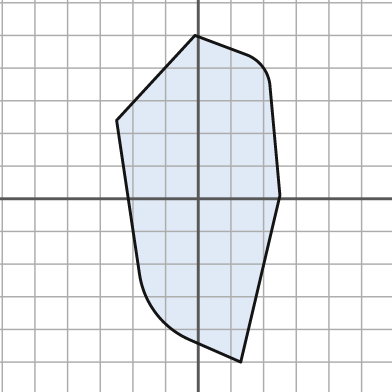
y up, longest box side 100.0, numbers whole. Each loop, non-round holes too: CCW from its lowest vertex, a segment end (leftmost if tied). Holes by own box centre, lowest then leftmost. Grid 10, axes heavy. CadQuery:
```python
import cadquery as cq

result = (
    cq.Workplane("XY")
    .moveTo(13.0, -50.0)
    .lineTo(25.0, 1.0)
    .lineTo(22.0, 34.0)
    .threePointArc((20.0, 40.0), (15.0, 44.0))
    .lineTo(-1.0, 50.0)
    .lineTo(-25.0, 24.0)
    .lineTo(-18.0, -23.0)
    .threePointArc((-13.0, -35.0), (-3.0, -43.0))
    .close()
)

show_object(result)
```